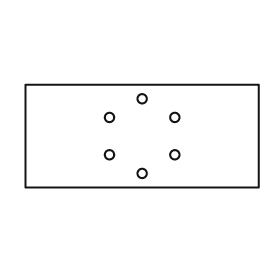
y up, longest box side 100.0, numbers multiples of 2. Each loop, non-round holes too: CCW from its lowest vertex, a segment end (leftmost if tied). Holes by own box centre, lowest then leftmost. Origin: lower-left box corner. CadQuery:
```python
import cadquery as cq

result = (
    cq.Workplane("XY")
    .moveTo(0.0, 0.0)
    .lineTo(100.0, 0.0)
    .lineTo(100.0, 44.0)
    .lineTo(0.0, 44.0)
    .close()
    .moveTo(50.0, 6.0)
    .circle(2.0)
    .moveTo(36.0, 14.0)
    .circle(2.0)
    .moveTo(64.0, 14.0)
    .circle(2.0)
    .moveTo(36.0, 30.0)
    .circle(2.0)
    .moveTo(64.0, 30.0)
    .circle(2.0)
    .moveTo(50.0, 38.0)
    .circle(2.0)
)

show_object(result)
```